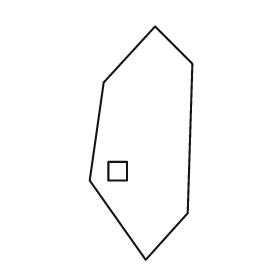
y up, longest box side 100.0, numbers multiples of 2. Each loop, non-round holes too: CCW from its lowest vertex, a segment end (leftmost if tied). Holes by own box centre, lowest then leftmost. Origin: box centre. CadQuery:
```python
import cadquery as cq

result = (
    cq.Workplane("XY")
    .moveTo(2.0, -50.0)
    .lineTo(20.0, -30.0)
    .lineTo(22.0, 34.0)
    .lineTo(6.0, 50.0)
    .lineTo(-16.0, 26.0)
    .lineTo(-22.0, -16.0)
    .close()
    .moveTo(-14.0, -16.0)
    .lineTo(-6.0, -16.0)
    .lineTo(-6.0, -8.0)
    .lineTo(-14.0, -8.0)
    .close()
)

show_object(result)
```